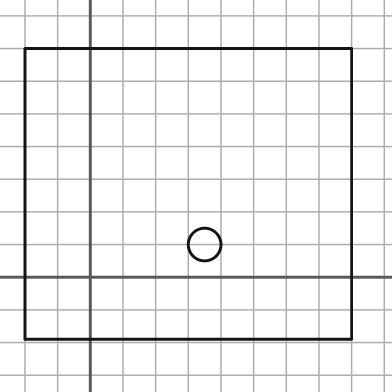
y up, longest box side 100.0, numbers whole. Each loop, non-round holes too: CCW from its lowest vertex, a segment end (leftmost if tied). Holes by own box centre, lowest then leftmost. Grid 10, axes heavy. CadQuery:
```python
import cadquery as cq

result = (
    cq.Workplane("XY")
    .moveTo(-20.0, -19.0)
    .lineTo(80.0, -19.0)
    .lineTo(80.0, 70.0)
    .lineTo(-20.0, 70.0)
    .close()
    .moveTo(35.0, 10.0)
    .circle(5.0)
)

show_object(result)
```